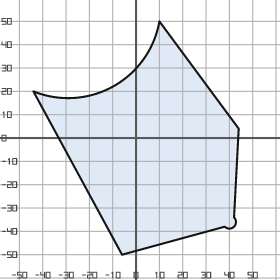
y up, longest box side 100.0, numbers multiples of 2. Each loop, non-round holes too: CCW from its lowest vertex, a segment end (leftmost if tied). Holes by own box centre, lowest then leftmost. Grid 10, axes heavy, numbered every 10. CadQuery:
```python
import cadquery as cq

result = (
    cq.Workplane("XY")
    .moveTo(-6.0, -50.0)
    .lineTo(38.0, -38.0)
    .threePointArc((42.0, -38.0), (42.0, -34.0))
    .lineTo(44.0, 4.0)
    .lineTo(10.0, 50.0)
    .threePointArc((-10.0, 22.0), (-44.0, 20.0))
    .close()
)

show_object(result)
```